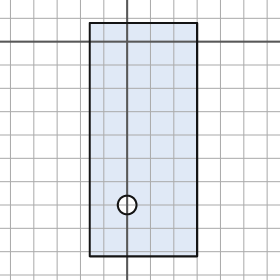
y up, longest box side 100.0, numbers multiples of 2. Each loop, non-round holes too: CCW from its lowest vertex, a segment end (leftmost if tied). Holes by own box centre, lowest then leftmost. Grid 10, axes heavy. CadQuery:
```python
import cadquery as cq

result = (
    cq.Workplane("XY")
    .moveTo(-16.0, -92.0)
    .lineTo(30.0, -92.0)
    .lineTo(30.0, 8.0)
    .lineTo(-16.0, 8.0)
    .close()
    .moveTo(0.0, -70.0)
    .circle(4.0)
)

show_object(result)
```